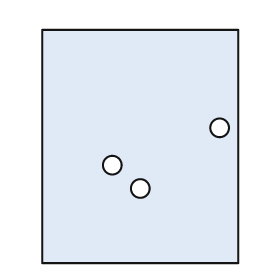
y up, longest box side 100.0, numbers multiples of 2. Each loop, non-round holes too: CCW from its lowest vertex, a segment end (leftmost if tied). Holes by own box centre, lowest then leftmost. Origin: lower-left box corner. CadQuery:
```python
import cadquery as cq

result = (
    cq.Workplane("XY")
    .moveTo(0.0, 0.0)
    .lineTo(84.0, 0.0)
    .lineTo(84.0, 100.0)
    .lineTo(0.0, 100.0)
    .close()
    .moveTo(42.0, 32.0)
    .circle(4.0)
    .moveTo(30.0, 42.0)
    .circle(4.0)
    .moveTo(76.0, 58.0)
    .circle(4.0)
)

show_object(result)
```